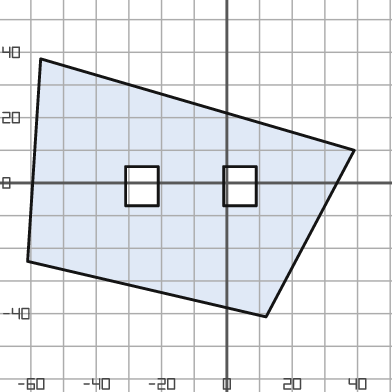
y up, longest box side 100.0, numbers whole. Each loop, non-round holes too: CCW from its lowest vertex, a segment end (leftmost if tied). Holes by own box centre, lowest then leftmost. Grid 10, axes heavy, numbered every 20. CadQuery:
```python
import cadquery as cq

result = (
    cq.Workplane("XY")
    .moveTo(12.0, -41.0)
    .lineTo(39.0, 10.0)
    .lineTo(-57.0, 38.0)
    .lineTo(-61.0, -24.0)
    .close()
    .moveTo(-31.0, -7.0)
    .lineTo(-21.0, -7.0)
    .lineTo(-21.0, 5.0)
    .lineTo(-31.0, 5.0)
    .close()
    .moveTo(-1.0, -7.0)
    .lineTo(9.0, -7.0)
    .lineTo(9.0, 5.0)
    .lineTo(-1.0, 5.0)
    .close()
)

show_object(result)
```